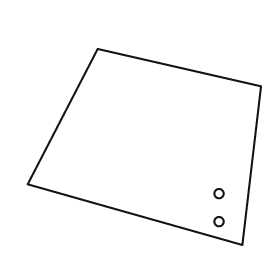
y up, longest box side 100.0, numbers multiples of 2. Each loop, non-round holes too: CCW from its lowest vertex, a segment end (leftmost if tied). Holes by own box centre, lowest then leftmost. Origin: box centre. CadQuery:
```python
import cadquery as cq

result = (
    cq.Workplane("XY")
    .moveTo(42.0, -42.0)
    .lineTo(50.0, 26.0)
    .lineTo(-20.0, 42.0)
    .lineTo(-50.0, -16.0)
    .close()
    .moveTo(32.0, -32.0)
    .circle(2.0)
    .moveTo(32.0, -20.0)
    .circle(2.0)
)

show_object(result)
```